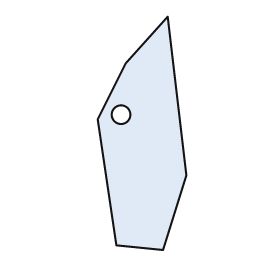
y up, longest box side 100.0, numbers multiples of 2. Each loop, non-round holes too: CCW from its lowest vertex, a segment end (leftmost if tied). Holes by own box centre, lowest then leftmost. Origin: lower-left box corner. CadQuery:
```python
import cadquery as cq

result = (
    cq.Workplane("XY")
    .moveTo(28.0, 0.0)
    .lineTo(38.0, 32.0)
    .lineTo(30.0, 100.0)
    .lineTo(12.0, 80.0)
    .lineTo(0.0, 56.0)
    .lineTo(8.0, 2.0)
    .close()
    .moveTo(10.0, 58.0)
    .circle(4.0)
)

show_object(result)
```